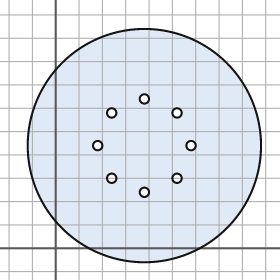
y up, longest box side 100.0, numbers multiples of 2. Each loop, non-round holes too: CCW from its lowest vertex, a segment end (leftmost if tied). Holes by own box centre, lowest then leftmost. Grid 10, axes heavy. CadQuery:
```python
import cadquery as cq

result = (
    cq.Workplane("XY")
    .moveTo(38.0, 44.0)
    .circle(50.0)
    .moveTo(38.0, 24.0)
    .circle(2.0)
    .moveTo(24.0, 30.0)
    .circle(2.0)
    .moveTo(52.0, 30.0)
    .circle(2.0)
    .moveTo(18.0, 44.0)
    .circle(2.0)
    .moveTo(58.0, 44.0)
    .circle(2.0)
    .moveTo(24.0, 58.0)
    .circle(2.0)
    .moveTo(52.0, 58.0)
    .circle(2.0)
    .moveTo(38.0, 64.0)
    .circle(2.0)
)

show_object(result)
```